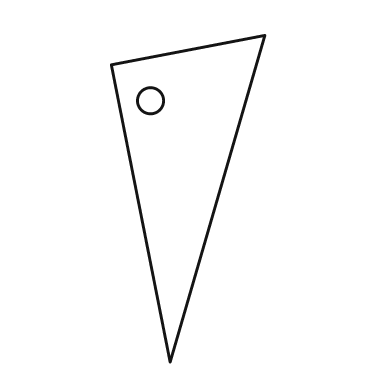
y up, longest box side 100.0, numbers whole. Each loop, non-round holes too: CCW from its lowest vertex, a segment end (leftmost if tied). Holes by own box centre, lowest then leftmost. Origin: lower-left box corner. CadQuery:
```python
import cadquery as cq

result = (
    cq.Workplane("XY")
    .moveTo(18.0, 0.0)
    .lineTo(47.0, 100.0)
    .lineTo(0.0, 91.0)
    .close()
    .moveTo(12.0, 80.0)
    .circle(4.0)
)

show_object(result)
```